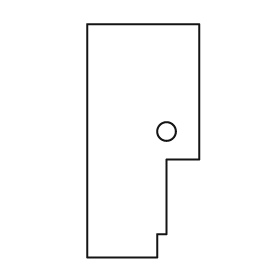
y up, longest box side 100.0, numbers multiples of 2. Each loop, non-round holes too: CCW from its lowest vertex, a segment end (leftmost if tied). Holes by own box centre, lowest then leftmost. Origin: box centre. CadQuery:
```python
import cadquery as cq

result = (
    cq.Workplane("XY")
    .moveTo(-24.0, -50.0)
    .lineTo(6.0, -50.0)
    .lineTo(6.0, -40.0)
    .lineTo(10.0, -40.0)
    .lineTo(10.0, -8.0)
    .lineTo(24.0, -8.0)
    .lineTo(24.0, 50.0)
    .lineTo(-24.0, 50.0)
    .close()
    .moveTo(10.0, 4.0)
    .circle(4.0)
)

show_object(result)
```